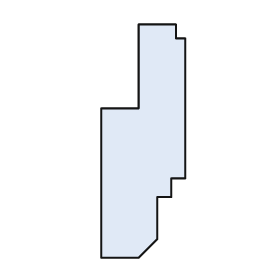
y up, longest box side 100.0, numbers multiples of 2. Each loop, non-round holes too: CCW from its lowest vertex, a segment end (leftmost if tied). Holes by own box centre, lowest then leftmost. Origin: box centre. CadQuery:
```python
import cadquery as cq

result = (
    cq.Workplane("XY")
    .moveTo(-18.0, -50.0)
    .lineTo(-2.0, -50.0)
    .lineTo(6.0, -42.0)
    .lineTo(6.0, -24.0)
    .lineTo(12.0, -24.0)
    .lineTo(12.0, -16.0)
    .lineTo(18.0, -16.0)
    .lineTo(18.0, 44.0)
    .lineTo(14.0, 44.0)
    .lineTo(14.0, 50.0)
    .lineTo(-2.0, 50.0)
    .lineTo(-2.0, 14.0)
    .lineTo(-18.0, 14.0)
    .close()
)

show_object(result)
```